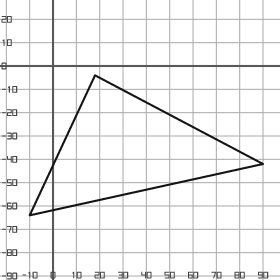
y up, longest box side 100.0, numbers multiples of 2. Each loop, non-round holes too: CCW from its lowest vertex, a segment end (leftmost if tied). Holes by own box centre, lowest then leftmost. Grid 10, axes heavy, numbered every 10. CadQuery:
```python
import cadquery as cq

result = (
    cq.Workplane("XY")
    .moveTo(-10.0, -64.0)
    .lineTo(90.0, -42.0)
    .lineTo(18.0, -4.0)
    .close()
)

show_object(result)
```